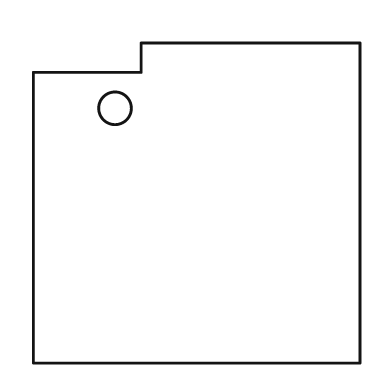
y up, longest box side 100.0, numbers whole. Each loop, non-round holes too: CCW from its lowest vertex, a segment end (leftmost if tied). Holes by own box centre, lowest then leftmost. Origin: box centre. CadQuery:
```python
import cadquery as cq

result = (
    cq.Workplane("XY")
    .moveTo(-50.0, -49.0)
    .lineTo(50.0, -49.0)
    .lineTo(50.0, 49.0)
    .lineTo(-17.0, 49.0)
    .lineTo(-17.0, 40.0)
    .lineTo(-50.0, 40.0)
    .close()
    .moveTo(-25.0, 29.0)
    .circle(5.0)
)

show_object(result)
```